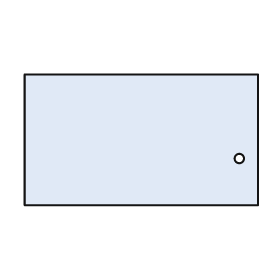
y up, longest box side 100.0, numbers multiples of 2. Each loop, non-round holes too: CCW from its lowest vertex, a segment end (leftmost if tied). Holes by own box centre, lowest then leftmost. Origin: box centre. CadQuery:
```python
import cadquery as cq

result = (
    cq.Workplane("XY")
    .moveTo(-50.0, -28.0)
    .lineTo(50.0, -28.0)
    .lineTo(50.0, 28.0)
    .lineTo(-50.0, 28.0)
    .close()
    .moveTo(42.0, -8.0)
    .circle(2.0)
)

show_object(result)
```